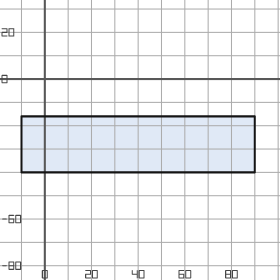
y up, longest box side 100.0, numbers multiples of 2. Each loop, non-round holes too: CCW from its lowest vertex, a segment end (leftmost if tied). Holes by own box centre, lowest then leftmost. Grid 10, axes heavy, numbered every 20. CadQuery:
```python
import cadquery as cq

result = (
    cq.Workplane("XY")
    .moveTo(-10.0, -40.0)
    .lineTo(90.0, -40.0)
    .lineTo(90.0, -16.0)
    .lineTo(-10.0, -16.0)
    .close()
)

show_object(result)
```